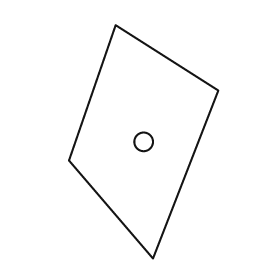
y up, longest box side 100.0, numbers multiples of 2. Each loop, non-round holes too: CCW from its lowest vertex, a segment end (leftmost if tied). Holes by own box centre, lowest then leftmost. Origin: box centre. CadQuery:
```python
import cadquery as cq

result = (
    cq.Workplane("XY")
    .moveTo(4.0, -50.0)
    .lineTo(32.0, 22.0)
    .lineTo(-12.0, 50.0)
    .lineTo(-32.0, -8.0)
    .close()
    .moveTo(0.0, 0.0)
    .circle(4.0)
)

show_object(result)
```